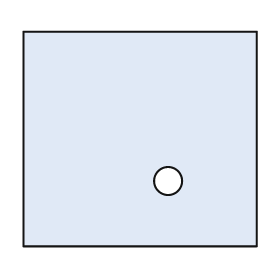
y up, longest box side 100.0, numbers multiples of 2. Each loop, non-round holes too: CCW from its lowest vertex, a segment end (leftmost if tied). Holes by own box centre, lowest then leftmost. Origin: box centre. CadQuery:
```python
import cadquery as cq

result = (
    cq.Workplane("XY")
    .moveTo(-50.0, -46.0)
    .lineTo(50.0, -46.0)
    .lineTo(50.0, 46.0)
    .lineTo(-50.0, 46.0)
    .close()
    .moveTo(12.0, -18.0)
    .circle(6.0)
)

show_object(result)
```